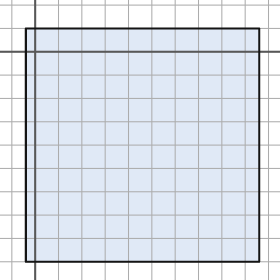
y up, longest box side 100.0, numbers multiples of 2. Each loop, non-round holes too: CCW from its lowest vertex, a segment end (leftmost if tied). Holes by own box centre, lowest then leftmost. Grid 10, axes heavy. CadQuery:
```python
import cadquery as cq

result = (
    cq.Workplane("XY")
    .moveTo(-4.0, -90.0)
    .lineTo(96.0, -90.0)
    .lineTo(96.0, 10.0)
    .lineTo(-4.0, 10.0)
    .close()
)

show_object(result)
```